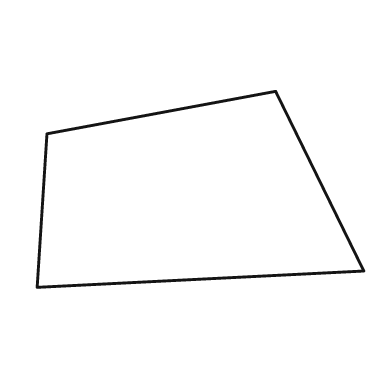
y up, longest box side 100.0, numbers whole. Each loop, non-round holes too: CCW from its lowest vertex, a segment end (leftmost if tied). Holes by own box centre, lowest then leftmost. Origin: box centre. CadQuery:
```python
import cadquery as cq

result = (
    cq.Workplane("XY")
    .moveTo(-50.0, -30.0)
    .lineTo(50.0, -25.0)
    .lineTo(23.0, 30.0)
    .lineTo(-47.0, 17.0)
    .close()
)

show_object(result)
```